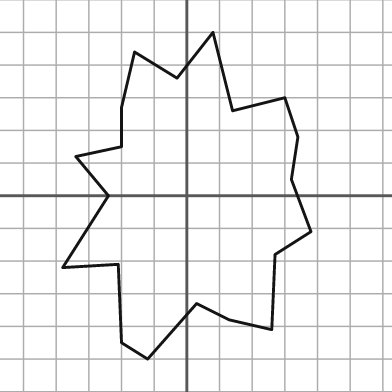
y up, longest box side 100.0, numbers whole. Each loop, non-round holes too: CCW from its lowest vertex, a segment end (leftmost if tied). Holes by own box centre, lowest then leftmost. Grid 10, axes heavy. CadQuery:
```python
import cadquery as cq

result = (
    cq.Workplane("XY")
    .moveTo(-12.0, -50.0)
    .lineTo(3.0, -33.0)
    .lineTo(13.0, -38.0)
    .lineTo(26.0, -41.0)
    .lineTo(27.0, -18.0)
    .lineTo(38.0, -11.0)
    .lineTo(32.0, 5.0)
    .lineTo(34.0, 18.0)
    .lineTo(30.0, 30.0)
    .lineTo(14.0, 26.0)
    .lineTo(8.0, 50.0)
    .lineTo(-3.0, 36.0)
    .lineTo(-16.0, 44.0)
    .lineTo(-20.0, 27.0)
    .lineTo(-20.0, 15.0)
    .lineTo(-34.0, 12.0)
    .lineTo(-24.0, 0.0)
    .lineTo(-38.0, -22.0)
    .lineTo(-21.0, -21.0)
    .lineTo(-20.0, -45.0)
    .close()
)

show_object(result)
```